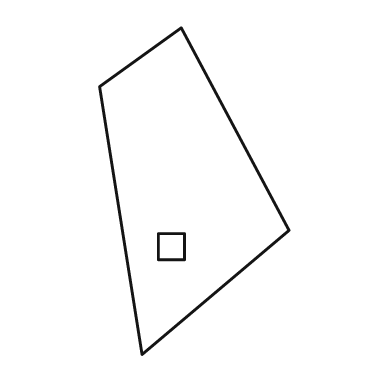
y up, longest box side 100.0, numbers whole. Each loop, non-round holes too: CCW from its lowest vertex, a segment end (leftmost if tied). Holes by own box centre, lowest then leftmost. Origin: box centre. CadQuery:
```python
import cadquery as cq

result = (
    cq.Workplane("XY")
    .moveTo(-16.0, -50.0)
    .lineTo(29.0, -12.0)
    .lineTo(-4.0, 50.0)
    .lineTo(-29.0, 32.0)
    .close()
    .moveTo(-11.0, -21.0)
    .lineTo(-3.0, -21.0)
    .lineTo(-3.0, -13.0)
    .lineTo(-11.0, -13.0)
    .close()
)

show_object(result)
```